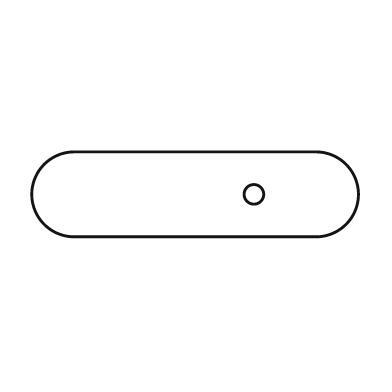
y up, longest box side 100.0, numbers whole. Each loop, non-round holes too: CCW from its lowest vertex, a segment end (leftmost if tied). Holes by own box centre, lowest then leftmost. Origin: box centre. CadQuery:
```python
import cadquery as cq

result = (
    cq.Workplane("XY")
    .moveTo(-37.0, -13.0)
    .lineTo(37.0, -13.0)
    .threePointArc((50.0, 0.0), (37.0, 13.0))
    .lineTo(-37.0, 13.0)
    .threePointArc((-50.0, 0.0), (-37.0, -13.0))
    .close()
    .moveTo(18.0, 0.0)
    .circle(3.0)
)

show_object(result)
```